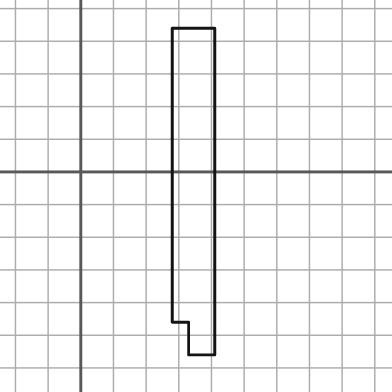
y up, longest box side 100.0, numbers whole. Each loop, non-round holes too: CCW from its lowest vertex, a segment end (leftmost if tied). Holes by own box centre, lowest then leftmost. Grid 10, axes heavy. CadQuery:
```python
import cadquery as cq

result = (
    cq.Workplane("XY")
    .moveTo(33.0, -56.0)
    .lineTo(41.0, -56.0)
    .lineTo(41.0, 44.0)
    .lineTo(28.0, 44.0)
    .lineTo(28.0, -46.0)
    .lineTo(33.0, -46.0)
    .close()
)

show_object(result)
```